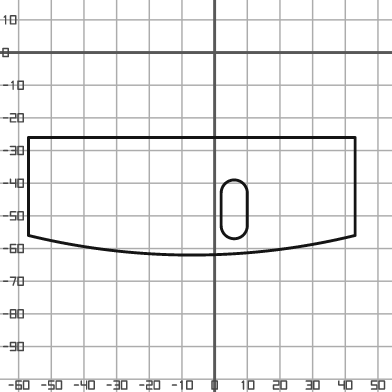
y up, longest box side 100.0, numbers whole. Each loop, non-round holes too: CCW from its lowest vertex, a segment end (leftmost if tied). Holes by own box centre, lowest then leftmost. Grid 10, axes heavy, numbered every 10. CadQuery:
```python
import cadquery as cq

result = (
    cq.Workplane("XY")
    .moveTo(-57.0, -56.0)
    .threePointArc((-7.0, -62.0), (43.0, -56.0))
    .lineTo(43.0, -26.0)
    .lineTo(-57.0, -26.0)
    .close()
    .moveTo(2.0, -53.0)
    .threePointArc((6.0, -57.0), (10.0, -53.0))
    .lineTo(10.0, -43.0)
    .threePointArc((6.0, -39.0), (2.0, -43.0))
    .close()
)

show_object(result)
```